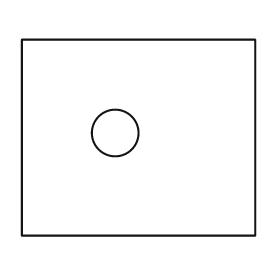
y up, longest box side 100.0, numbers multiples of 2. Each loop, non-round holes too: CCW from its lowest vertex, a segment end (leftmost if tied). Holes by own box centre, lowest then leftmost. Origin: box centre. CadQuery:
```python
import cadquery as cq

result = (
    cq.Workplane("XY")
    .moveTo(-50.0, -42.0)
    .lineTo(50.0, -42.0)
    .lineTo(50.0, 42.0)
    .lineTo(-50.0, 42.0)
    .close()
    .moveTo(-10.0, 2.0)
    .circle(10.0)
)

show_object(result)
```